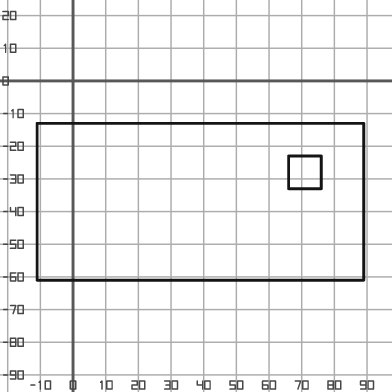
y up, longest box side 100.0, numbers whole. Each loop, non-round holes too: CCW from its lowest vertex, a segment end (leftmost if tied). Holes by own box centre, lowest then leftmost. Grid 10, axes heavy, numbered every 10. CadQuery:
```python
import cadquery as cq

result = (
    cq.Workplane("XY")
    .moveTo(-11.0, -61.0)
    .lineTo(89.0, -61.0)
    .lineTo(89.0, -13.0)
    .lineTo(-11.0, -13.0)
    .close()
    .moveTo(66.0, -33.0)
    .lineTo(76.0, -33.0)
    .lineTo(76.0, -23.0)
    .lineTo(66.0, -23.0)
    .close()
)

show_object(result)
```